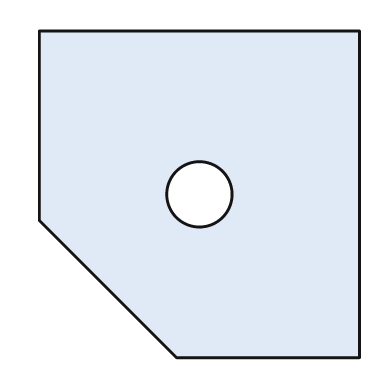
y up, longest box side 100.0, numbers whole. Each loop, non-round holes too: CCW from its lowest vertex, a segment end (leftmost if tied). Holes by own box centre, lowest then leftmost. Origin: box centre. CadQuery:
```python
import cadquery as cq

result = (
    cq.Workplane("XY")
    .moveTo(-7.0, -50.0)
    .lineTo(49.0, -50.0)
    .lineTo(49.0, 50.0)
    .lineTo(-49.0, 50.0)
    .lineTo(-49.0, -8.0)
    .close()
    .moveTo(0.0, 0.0)
    .circle(10.0)
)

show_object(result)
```